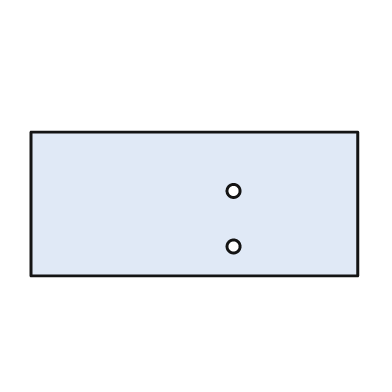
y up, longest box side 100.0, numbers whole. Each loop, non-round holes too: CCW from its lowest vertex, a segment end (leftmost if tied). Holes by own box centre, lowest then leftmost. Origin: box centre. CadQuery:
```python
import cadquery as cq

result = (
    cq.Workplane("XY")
    .moveTo(-50.0, -22.0)
    .lineTo(50.0, -22.0)
    .lineTo(50.0, 22.0)
    .lineTo(-50.0, 22.0)
    .close()
    .moveTo(12.0, -13.0)
    .circle(2.0)
    .moveTo(12.0, 4.0)
    .circle(2.0)
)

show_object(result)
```